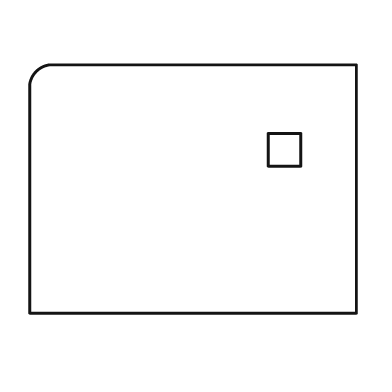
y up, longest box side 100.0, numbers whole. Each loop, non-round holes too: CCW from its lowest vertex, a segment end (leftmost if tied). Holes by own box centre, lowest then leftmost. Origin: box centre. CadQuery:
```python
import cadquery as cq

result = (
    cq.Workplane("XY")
    .moveTo(-50.0, -38.0)
    .lineTo(50.0, -38.0)
    .lineTo(50.0, 38.0)
    .lineTo(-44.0, 38.0)
    .threePointArc((-48.0, 36.0), (-50.0, 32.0))
    .close()
    .moveTo(23.0, 7.0)
    .lineTo(33.0, 7.0)
    .lineTo(33.0, 17.0)
    .lineTo(23.0, 17.0)
    .close()
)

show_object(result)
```